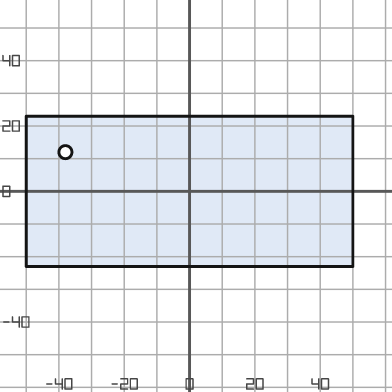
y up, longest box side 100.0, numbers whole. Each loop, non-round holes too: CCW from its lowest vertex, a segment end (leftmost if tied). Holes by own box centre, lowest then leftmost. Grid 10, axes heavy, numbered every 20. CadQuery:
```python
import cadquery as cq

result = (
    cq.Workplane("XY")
    .moveTo(-50.0, -23.0)
    .lineTo(50.0, -23.0)
    .lineTo(50.0, 23.0)
    .lineTo(-50.0, 23.0)
    .close()
    .moveTo(-38.0, 12.0)
    .circle(2.0)
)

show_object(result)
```